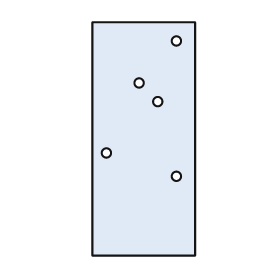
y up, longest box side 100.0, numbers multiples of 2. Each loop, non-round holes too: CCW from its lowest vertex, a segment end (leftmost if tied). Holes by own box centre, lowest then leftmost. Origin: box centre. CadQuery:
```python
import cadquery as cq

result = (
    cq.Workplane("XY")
    .moveTo(-22.0, -50.0)
    .lineTo(22.0, -50.0)
    .lineTo(22.0, 50.0)
    .lineTo(-22.0, 50.0)
    .close()
    .moveTo(14.0, -16.0)
    .circle(2.0)
    .moveTo(-16.0, -6.0)
    .circle(2.0)
    .moveTo(6.0, 16.0)
    .circle(2.0)
    .moveTo(-2.0, 24.0)
    .circle(2.0)
    .moveTo(14.0, 42.0)
    .circle(2.0)
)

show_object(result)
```